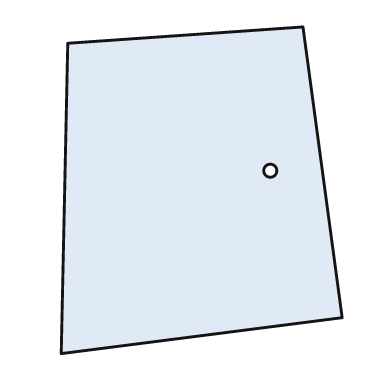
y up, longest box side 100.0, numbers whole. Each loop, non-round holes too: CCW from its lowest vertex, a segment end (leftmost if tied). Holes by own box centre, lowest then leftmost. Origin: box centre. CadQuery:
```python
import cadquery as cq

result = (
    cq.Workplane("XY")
    .moveTo(-43.0, -50.0)
    .lineTo(43.0, -39.0)
    .lineTo(31.0, 50.0)
    .lineTo(-41.0, 45.0)
    .close()
    .moveTo(21.0, 6.0)
    .circle(2.0)
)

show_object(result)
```